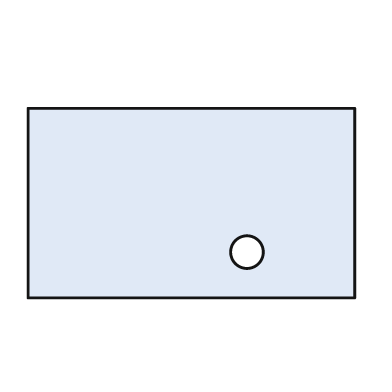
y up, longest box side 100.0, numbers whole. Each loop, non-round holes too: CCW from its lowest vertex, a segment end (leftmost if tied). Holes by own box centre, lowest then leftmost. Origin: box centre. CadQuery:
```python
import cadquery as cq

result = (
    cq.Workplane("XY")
    .moveTo(-50.0, -29.0)
    .lineTo(50.0, -29.0)
    .lineTo(50.0, 29.0)
    .lineTo(-50.0, 29.0)
    .close()
    .moveTo(17.0, -15.0)
    .circle(5.0)
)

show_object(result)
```